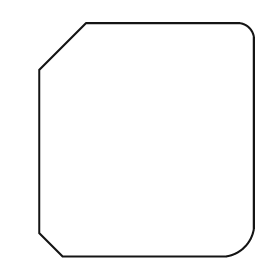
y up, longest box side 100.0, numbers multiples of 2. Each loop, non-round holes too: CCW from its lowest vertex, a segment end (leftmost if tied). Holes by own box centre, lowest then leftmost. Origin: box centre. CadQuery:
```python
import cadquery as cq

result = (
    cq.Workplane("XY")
    .moveTo(-36.0, -50.0)
    .lineTo(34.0, -50.0)
    .threePointArc((42.0, -46.0), (46.0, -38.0))
    .lineTo(46.0, 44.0)
    .threePointArc((44.0, 48.0), (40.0, 50.0))
    .lineTo(-26.0, 50.0)
    .lineTo(-46.0, 30.0)
    .lineTo(-46.0, -40.0)
    .close()
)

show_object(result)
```